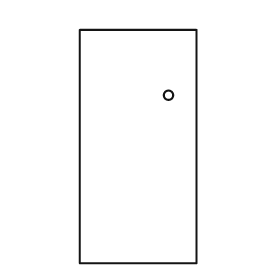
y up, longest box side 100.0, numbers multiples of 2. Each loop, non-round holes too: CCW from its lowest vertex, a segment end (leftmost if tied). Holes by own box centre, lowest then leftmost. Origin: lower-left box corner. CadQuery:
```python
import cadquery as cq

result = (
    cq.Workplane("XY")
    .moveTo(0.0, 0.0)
    .lineTo(50.0, 0.0)
    .lineTo(50.0, 100.0)
    .lineTo(0.0, 100.0)
    .close()
    .moveTo(38.0, 72.0)
    .circle(2.0)
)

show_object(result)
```